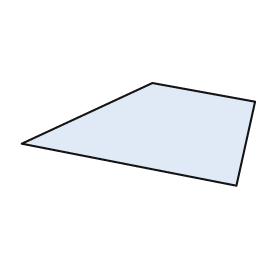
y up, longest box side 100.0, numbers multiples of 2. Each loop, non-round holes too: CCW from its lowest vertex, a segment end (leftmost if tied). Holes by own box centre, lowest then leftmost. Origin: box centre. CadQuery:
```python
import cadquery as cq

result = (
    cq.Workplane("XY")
    .moveTo(42.0, -22.0)
    .lineTo(50.0, 14.0)
    .lineTo(6.0, 22.0)
    .lineTo(-50.0, -4.0)
    .close()
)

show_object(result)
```